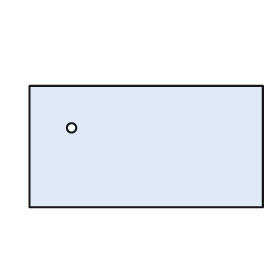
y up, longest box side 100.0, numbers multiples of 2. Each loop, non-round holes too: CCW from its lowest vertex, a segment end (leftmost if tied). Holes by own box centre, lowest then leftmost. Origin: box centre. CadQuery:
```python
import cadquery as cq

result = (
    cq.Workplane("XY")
    .moveTo(-50.0, -26.0)
    .lineTo(50.0, -26.0)
    .lineTo(50.0, 26.0)
    .lineTo(-50.0, 26.0)
    .close()
    .moveTo(-32.0, 8.0)
    .circle(2.0)
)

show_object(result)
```